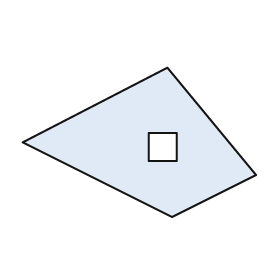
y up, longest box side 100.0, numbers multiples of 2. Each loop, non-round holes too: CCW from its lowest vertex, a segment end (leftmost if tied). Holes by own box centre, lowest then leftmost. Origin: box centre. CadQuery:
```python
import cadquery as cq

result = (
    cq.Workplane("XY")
    .moveTo(14.0, -32.0)
    .lineTo(50.0, -14.0)
    .lineTo(12.0, 32.0)
    .lineTo(-50.0, 0.0)
    .close()
    .moveTo(4.0, -8.0)
    .lineTo(16.0, -8.0)
    .lineTo(16.0, 4.0)
    .lineTo(4.0, 4.0)
    .close()
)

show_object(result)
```